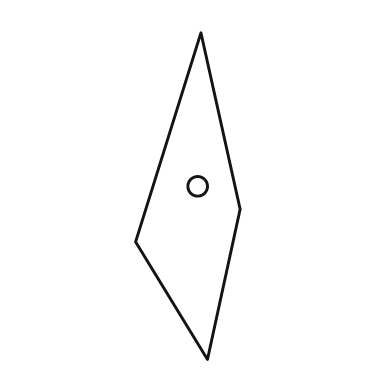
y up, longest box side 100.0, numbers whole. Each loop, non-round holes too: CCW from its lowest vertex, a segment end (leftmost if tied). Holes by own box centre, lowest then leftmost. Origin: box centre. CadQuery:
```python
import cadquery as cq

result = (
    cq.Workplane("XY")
    .moveTo(6.0, -50.0)
    .lineTo(16.0, -4.0)
    .lineTo(4.0, 50.0)
    .lineTo(-16.0, -14.0)
    .close()
    .moveTo(3.0, 3.0)
    .circle(3.0)
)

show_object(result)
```